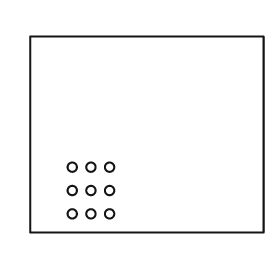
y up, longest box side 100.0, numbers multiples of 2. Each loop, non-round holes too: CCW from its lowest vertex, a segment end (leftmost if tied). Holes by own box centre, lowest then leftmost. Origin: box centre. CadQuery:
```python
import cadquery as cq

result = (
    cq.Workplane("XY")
    .moveTo(-50.0, -42.0)
    .lineTo(50.0, -42.0)
    .lineTo(50.0, 42.0)
    .lineTo(-50.0, 42.0)
    .close()
    .moveTo(-32.0, -34.0)
    .circle(2.0)
    .moveTo(-24.0, -34.0)
    .circle(2.0)
    .moveTo(-16.0, -34.0)
    .circle(2.0)
    .moveTo(-32.0, -24.0)
    .circle(2.0)
    .moveTo(-24.0, -24.0)
    .circle(2.0)
    .moveTo(-16.0, -24.0)
    .circle(2.0)
    .moveTo(-32.0, -14.0)
    .circle(2.0)
    .moveTo(-24.0, -14.0)
    .circle(2.0)
    .moveTo(-16.0, -14.0)
    .circle(2.0)
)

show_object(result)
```